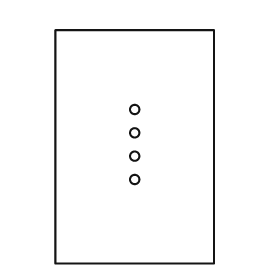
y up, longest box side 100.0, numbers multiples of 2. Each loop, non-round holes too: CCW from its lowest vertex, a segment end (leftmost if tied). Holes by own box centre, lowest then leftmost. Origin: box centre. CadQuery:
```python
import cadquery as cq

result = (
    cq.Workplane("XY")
    .moveTo(-34.0, -50.0)
    .lineTo(34.0, -50.0)
    .lineTo(34.0, 50.0)
    .lineTo(-34.0, 50.0)
    .close()
    .moveTo(0.0, -14.0)
    .circle(2.0)
    .moveTo(0.0, -4.0)
    .circle(2.0)
    .moveTo(0.0, 6.0)
    .circle(2.0)
    .moveTo(0.0, 16.0)
    .circle(2.0)
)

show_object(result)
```